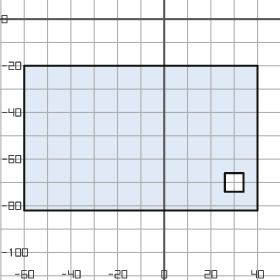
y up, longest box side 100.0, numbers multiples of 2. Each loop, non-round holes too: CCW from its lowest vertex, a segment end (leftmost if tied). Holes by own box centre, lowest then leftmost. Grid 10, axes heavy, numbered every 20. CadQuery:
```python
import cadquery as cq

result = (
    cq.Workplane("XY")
    .moveTo(-60.0, -82.0)
    .lineTo(40.0, -82.0)
    .lineTo(40.0, -20.0)
    .lineTo(-60.0, -20.0)
    .close()
    .moveTo(26.0, -74.0)
    .lineTo(34.0, -74.0)
    .lineTo(34.0, -66.0)
    .lineTo(26.0, -66.0)
    .close()
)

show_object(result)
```